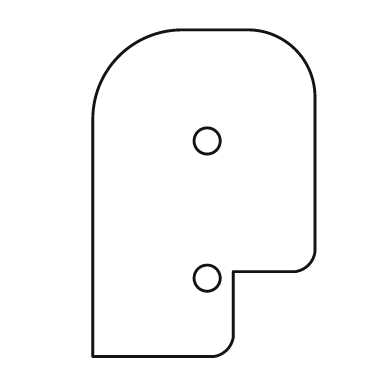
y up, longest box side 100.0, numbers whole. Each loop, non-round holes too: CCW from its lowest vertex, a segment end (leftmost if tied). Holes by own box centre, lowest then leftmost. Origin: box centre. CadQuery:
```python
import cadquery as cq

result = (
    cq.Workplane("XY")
    .moveTo(-34.0, -50.0)
    .lineTo(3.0, -50.0)
    .threePointArc((7.0, -48.0), (9.0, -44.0))
    .lineTo(9.0, -24.0)
    .lineTo(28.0, -24.0)
    .threePointArc((32.0, -22.0), (34.0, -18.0))
    .lineTo(34.0, 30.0)
    .threePointArc((28.0, 44.0), (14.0, 50.0))
    .lineTo(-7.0, 50.0)
    .threePointArc((-26.0, 42.0), (-34.0, 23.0))
    .close()
    .moveTo(1.0, -26.0)
    .circle(4.0)
    .moveTo(1.0, 16.0)
    .circle(4.0)
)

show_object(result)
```